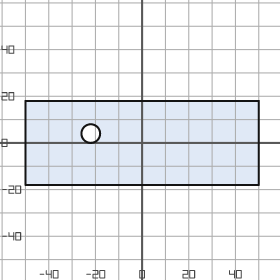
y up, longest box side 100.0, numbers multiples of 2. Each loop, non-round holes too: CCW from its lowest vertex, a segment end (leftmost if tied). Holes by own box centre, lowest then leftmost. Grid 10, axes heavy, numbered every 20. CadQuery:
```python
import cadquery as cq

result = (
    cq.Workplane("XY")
    .moveTo(-50.0, -18.0)
    .lineTo(50.0, -18.0)
    .lineTo(50.0, 18.0)
    .lineTo(-50.0, 18.0)
    .close()
    .moveTo(-22.0, 4.0)
    .circle(4.0)
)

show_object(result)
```